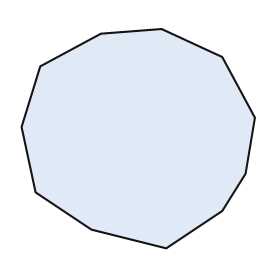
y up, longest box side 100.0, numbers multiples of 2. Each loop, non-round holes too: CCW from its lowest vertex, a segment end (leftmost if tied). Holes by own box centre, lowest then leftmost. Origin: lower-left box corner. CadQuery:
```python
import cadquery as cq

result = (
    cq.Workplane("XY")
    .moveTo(62.0, 0.0)
    .lineTo(86.0, 16.0)
    .lineTo(96.0, 32.0)
    .lineTo(100.0, 56.0)
    .lineTo(86.0, 82.0)
    .lineTo(60.0, 94.0)
    .lineTo(34.0, 92.0)
    .lineTo(8.0, 78.0)
    .lineTo(0.0, 52.0)
    .lineTo(6.0, 24.0)
    .lineTo(30.0, 8.0)
    .close()
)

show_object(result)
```